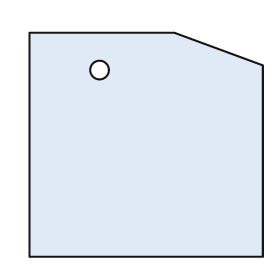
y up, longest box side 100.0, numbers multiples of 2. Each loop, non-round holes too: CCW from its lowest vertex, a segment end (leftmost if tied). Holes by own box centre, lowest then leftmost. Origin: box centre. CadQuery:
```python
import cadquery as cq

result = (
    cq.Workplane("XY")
    .moveTo(-50.0, -48.0)
    .lineTo(50.0, -48.0)
    .lineTo(50.0, 34.0)
    .lineTo(12.0, 48.0)
    .lineTo(-50.0, 48.0)
    .close()
    .moveTo(-20.0, 32.0)
    .circle(4.0)
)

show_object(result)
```